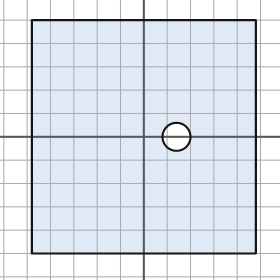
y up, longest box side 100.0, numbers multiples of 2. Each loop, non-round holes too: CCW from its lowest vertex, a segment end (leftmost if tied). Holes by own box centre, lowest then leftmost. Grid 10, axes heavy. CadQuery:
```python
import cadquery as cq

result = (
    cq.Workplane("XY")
    .moveTo(-48.0, -50.0)
    .lineTo(48.0, -50.0)
    .lineTo(48.0, 50.0)
    .lineTo(-48.0, 50.0)
    .close()
    .moveTo(14.0, 0.0)
    .circle(6.0)
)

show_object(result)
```